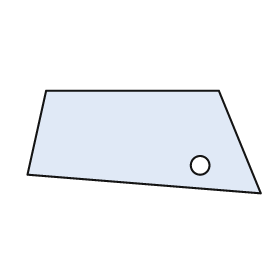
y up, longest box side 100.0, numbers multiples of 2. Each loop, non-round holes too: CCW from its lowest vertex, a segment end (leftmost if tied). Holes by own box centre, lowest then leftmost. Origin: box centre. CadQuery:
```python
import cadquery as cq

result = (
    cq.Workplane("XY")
    .moveTo(50.0, -22.0)
    .lineTo(32.0, 22.0)
    .lineTo(-42.0, 22.0)
    .lineTo(-50.0, -14.0)
    .close()
    .moveTo(24.0, -10.0)
    .circle(4.0)
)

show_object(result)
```